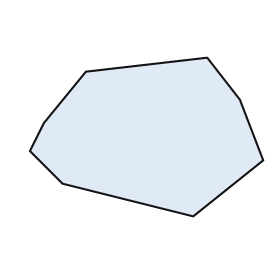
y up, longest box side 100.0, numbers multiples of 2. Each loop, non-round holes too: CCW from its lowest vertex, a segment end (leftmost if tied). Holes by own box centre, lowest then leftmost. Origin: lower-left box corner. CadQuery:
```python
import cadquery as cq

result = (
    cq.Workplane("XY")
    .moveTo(70.0, 0.0)
    .lineTo(100.0, 24.0)
    .lineTo(90.0, 50.0)
    .lineTo(76.0, 68.0)
    .lineTo(24.0, 62.0)
    .lineTo(6.0, 40.0)
    .lineTo(0.0, 28.0)
    .lineTo(14.0, 14.0)
    .close()
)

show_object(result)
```